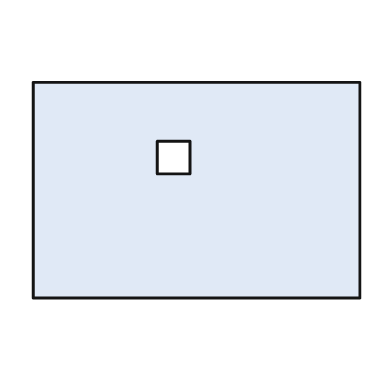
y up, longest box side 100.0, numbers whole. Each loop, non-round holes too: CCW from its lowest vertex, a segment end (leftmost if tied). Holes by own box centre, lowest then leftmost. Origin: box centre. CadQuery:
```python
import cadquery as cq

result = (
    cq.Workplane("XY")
    .moveTo(-50.0, -33.0)
    .lineTo(50.0, -33.0)
    .lineTo(50.0, 33.0)
    .lineTo(-50.0, 33.0)
    .close()
    .moveTo(-12.0, 5.0)
    .lineTo(-2.0, 5.0)
    .lineTo(-2.0, 15.0)
    .lineTo(-12.0, 15.0)
    .close()
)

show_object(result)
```